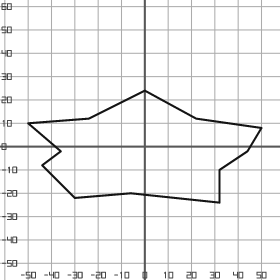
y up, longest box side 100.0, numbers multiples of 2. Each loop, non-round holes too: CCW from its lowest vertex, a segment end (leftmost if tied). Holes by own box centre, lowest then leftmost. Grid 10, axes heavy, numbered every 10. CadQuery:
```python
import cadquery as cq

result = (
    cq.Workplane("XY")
    .moveTo(32.0, -24.0)
    .lineTo(32.0, -10.0)
    .lineTo(44.0, -2.0)
    .lineTo(50.0, 8.0)
    .lineTo(22.0, 12.0)
    .lineTo(0.0, 24.0)
    .lineTo(-24.0, 12.0)
    .lineTo(-50.0, 10.0)
    .lineTo(-36.0, -2.0)
    .lineTo(-44.0, -8.0)
    .lineTo(-30.0, -22.0)
    .lineTo(-6.0, -20.0)
    .close()
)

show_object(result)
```